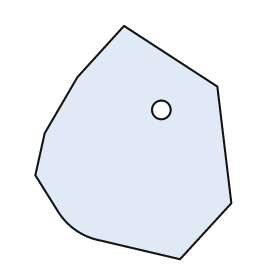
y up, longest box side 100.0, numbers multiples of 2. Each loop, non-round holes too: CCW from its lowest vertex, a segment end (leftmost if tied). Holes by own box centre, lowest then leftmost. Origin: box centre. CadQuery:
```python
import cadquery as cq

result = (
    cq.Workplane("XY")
    .moveTo(20.0, -50.0)
    .lineTo(42.0, -26.0)
    .lineTo(36.0, 24.0)
    .lineTo(-4.0, 50.0)
    .lineTo(-24.0, 28.0)
    .lineTo(-38.0, 4.0)
    .lineTo(-42.0, -14.0)
    .lineTo(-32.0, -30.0)
    .threePointArc((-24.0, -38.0), (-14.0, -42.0))
    .close()
    .moveTo(12.0, 14.0)
    .circle(4.0)
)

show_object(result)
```